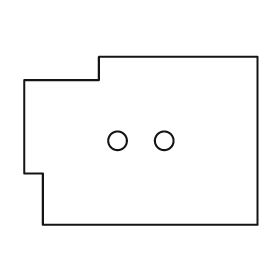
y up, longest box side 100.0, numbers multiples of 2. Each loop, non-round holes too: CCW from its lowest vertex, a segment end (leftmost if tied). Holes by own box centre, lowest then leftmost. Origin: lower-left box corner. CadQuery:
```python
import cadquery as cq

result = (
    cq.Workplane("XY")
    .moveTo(8.0, 0.0)
    .lineTo(100.0, 0.0)
    .lineTo(100.0, 72.0)
    .lineTo(32.0, 72.0)
    .lineTo(32.0, 62.0)
    .lineTo(0.0, 62.0)
    .lineTo(0.0, 22.0)
    .lineTo(8.0, 22.0)
    .close()
    .moveTo(40.0, 36.0)
    .circle(4.0)
    .moveTo(60.0, 36.0)
    .circle(4.0)
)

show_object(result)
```